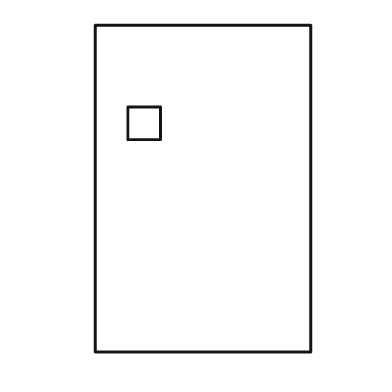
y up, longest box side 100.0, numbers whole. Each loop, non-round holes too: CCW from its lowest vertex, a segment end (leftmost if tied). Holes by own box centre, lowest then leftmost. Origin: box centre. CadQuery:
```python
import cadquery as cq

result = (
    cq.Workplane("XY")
    .moveTo(-33.0, -50.0)
    .lineTo(33.0, -50.0)
    .lineTo(33.0, 50.0)
    .lineTo(-33.0, 50.0)
    .close()
    .moveTo(-23.0, 15.0)
    .lineTo(-13.0, 15.0)
    .lineTo(-13.0, 25.0)
    .lineTo(-23.0, 25.0)
    .close()
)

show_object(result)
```